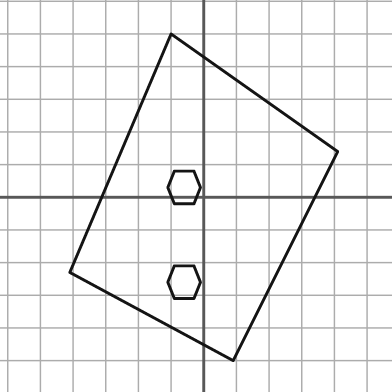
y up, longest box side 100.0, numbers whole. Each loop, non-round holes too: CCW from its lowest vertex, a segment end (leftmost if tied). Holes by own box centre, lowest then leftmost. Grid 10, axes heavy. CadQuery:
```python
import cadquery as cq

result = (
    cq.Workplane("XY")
    .moveTo(9.0, -50.0)
    .lineTo(41.0, 14.0)
    .lineTo(-10.0, 50.0)
    .lineTo(-41.0, -23.0)
    .close()
    .moveTo(-9.0, -31.0)
    .lineTo(-3.0, -31.0)
    .lineTo(-1.0, -26.0)
    .lineTo(-3.0, -21.0)
    .lineTo(-9.0, -21.0)
    .lineTo(-11.0, -26.0)
    .close()
    .moveTo(-9.0, -2.0)
    .lineTo(-3.0, -2.0)
    .lineTo(-1.0, 3.0)
    .lineTo(-3.0, 8.0)
    .lineTo(-9.0, 8.0)
    .lineTo(-11.0, 3.0)
    .close()
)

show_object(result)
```